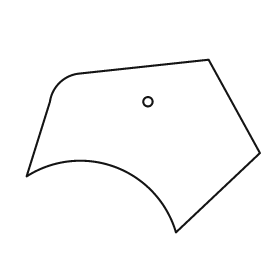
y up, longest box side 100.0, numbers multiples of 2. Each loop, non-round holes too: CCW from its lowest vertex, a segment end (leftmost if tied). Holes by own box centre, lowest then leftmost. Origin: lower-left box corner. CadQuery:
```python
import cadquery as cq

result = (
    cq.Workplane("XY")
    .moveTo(64.0, 0.0)
    .lineTo(100.0, 34.0)
    .lineTo(78.0, 74.0)
    .lineTo(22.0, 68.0)
    .threePointArc((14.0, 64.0), (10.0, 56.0))
    .lineTo(0.0, 24.0)
    .threePointArc((38.0, 28.0), (64.0, 0.0))
    .close()
    .moveTo(52.0, 56.0)
    .circle(2.0)
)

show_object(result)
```